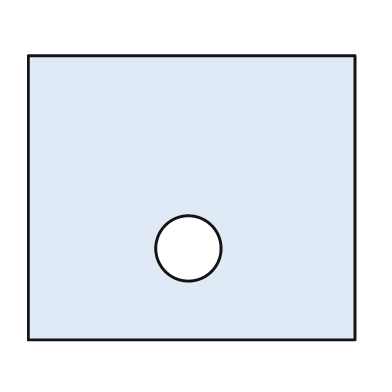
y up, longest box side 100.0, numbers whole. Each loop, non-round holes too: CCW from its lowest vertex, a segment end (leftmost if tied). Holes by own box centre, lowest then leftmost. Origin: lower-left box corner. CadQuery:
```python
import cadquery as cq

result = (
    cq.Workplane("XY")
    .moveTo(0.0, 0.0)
    .lineTo(100.0, 0.0)
    .lineTo(100.0, 87.0)
    .lineTo(0.0, 87.0)
    .close()
    .moveTo(49.0, 28.0)
    .circle(10.0)
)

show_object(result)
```